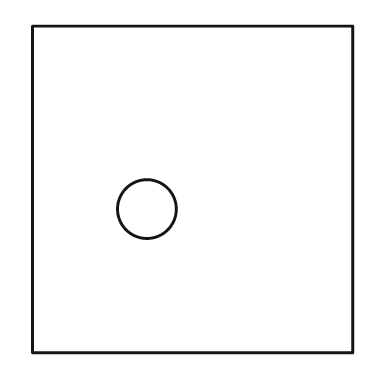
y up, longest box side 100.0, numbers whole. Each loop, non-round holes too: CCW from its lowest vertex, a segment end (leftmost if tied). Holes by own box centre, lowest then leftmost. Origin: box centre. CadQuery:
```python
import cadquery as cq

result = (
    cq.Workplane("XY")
    .moveTo(-49.0, -50.0)
    .lineTo(49.0, -50.0)
    .lineTo(49.0, 50.0)
    .lineTo(-49.0, 50.0)
    .close()
    .moveTo(-14.0, -6.0)
    .circle(9.0)
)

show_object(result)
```